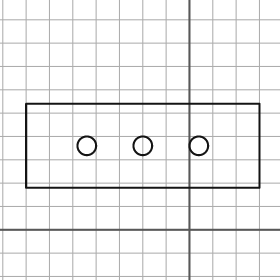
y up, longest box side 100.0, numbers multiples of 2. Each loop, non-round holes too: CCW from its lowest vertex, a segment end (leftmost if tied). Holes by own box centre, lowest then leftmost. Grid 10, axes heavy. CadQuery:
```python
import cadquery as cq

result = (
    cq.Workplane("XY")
    .moveTo(-70.0, 18.0)
    .lineTo(30.0, 18.0)
    .lineTo(30.0, 54.0)
    .lineTo(-70.0, 54.0)
    .close()
    .moveTo(-44.0, 36.0)
    .circle(4.0)
    .moveTo(-20.0, 36.0)
    .circle(4.0)
    .moveTo(4.0, 36.0)
    .circle(4.0)
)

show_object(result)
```